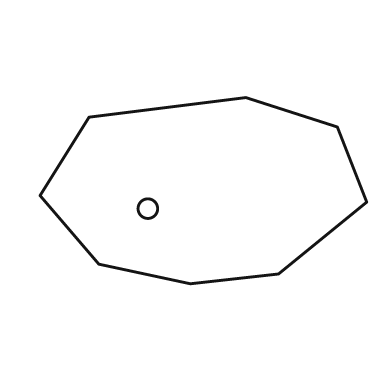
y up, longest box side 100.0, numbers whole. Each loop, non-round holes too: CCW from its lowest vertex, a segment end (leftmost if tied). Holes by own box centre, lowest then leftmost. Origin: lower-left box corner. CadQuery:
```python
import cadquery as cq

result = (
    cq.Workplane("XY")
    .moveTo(46.0, 0.0)
    .lineTo(73.0, 3.0)
    .lineTo(100.0, 25.0)
    .lineTo(91.0, 48.0)
    .lineTo(63.0, 57.0)
    .lineTo(15.0, 51.0)
    .lineTo(0.0, 27.0)
    .lineTo(18.0, 6.0)
    .close()
    .moveTo(33.0, 23.0)
    .circle(3.0)
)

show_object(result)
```